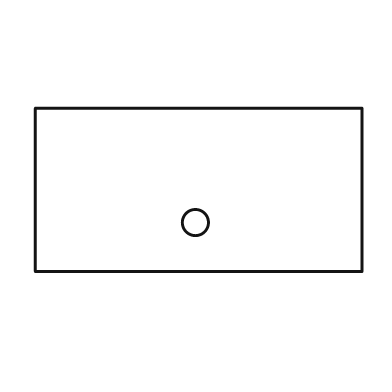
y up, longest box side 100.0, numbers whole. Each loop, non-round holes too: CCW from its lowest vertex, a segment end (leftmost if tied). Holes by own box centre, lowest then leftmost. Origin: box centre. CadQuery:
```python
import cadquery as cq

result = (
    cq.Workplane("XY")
    .moveTo(-50.0, -25.0)
    .lineTo(50.0, -25.0)
    .lineTo(50.0, 25.0)
    .lineTo(-50.0, 25.0)
    .close()
    .moveTo(-1.0, -10.0)
    .circle(4.0)
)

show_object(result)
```